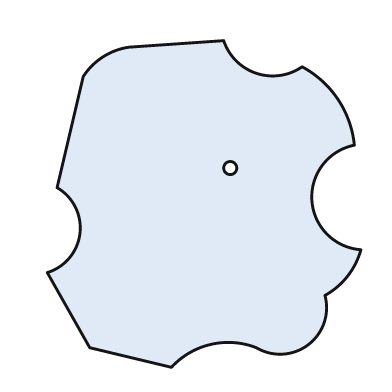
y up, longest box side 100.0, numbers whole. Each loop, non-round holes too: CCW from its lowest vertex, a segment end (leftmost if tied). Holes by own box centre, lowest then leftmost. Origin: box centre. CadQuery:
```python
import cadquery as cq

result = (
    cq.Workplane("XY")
    .moveTo(-10.0, -50.0)
    .threePointArc((2.0, -43.0), (16.0, -44.0))
    .threePointArc((32.0, -43.0), (37.0, -28.0))
    .threePointArc((44.0, -22.0), (48.0, -14.0))
    .threePointArc((33.0, 1.0), (46.0, 18.0))
    .threePointArc((41.0, 32.0), (30.0, 42.0))
    .threePointArc((16.0, 40.0), (6.0, 50.0))
    .lineTo(-23.0, 48.0)
    .threePointArc((-31.0, 45.0), (-37.0, 39.0))
    .lineTo(-45.0, 5.0)
    .threePointArc((-38.0, -9.0), (-48.0, -21.0))
    .lineTo(-35.0, -44.0)
    .close()
    .moveTo(8.0, 11.0)
    .circle(2.0)
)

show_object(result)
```